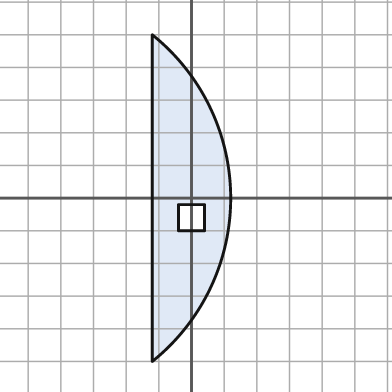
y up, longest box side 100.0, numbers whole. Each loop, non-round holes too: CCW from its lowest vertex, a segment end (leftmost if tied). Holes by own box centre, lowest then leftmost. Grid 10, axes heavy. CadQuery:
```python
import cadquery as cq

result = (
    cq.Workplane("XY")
    .moveTo(-12.0, -50.0)
    .threePointArc((12.0, 0.0), (-12.0, 50.0))
    .close()
    .moveTo(-4.0, -10.0)
    .lineTo(4.0, -10.0)
    .lineTo(4.0, -2.0)
    .lineTo(-4.0, -2.0)
    .close()
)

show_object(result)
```